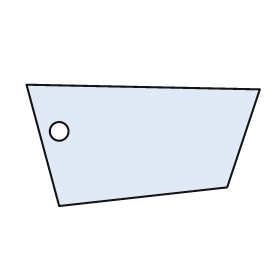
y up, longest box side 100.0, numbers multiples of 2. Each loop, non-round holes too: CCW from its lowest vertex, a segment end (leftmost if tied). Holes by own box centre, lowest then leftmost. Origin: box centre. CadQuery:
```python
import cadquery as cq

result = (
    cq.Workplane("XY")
    .moveTo(-36.0, -26.0)
    .lineTo(36.0, -18.0)
    .lineTo(50.0, 24.0)
    .lineTo(-50.0, 26.0)
    .close()
    .moveTo(-36.0, 6.0)
    .circle(4.0)
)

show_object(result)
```